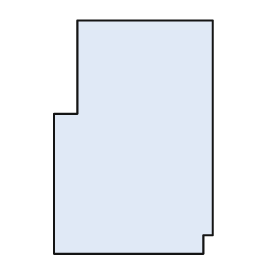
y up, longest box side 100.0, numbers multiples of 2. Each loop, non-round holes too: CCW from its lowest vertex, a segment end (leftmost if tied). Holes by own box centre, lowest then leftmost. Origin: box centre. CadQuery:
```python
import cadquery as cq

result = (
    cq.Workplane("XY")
    .moveTo(-34.0, -50.0)
    .lineTo(30.0, -50.0)
    .lineTo(30.0, -42.0)
    .lineTo(34.0, -42.0)
    .lineTo(34.0, 50.0)
    .lineTo(-24.0, 50.0)
    .lineTo(-24.0, 10.0)
    .lineTo(-34.0, 10.0)
    .close()
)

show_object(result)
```